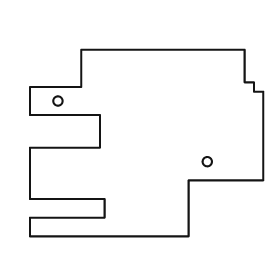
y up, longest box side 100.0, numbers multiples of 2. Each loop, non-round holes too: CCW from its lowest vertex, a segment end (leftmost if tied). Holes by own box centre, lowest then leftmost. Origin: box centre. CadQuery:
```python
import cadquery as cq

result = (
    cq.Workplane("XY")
    .moveTo(-50.0, -40.0)
    .lineTo(18.0, -40.0)
    .lineTo(18.0, -16.0)
    .lineTo(50.0, -16.0)
    .lineTo(50.0, 22.0)
    .lineTo(46.0, 22.0)
    .lineTo(46.0, 26.0)
    .lineTo(42.0, 26.0)
    .lineTo(42.0, 40.0)
    .lineTo(-28.0, 40.0)
    .lineTo(-28.0, 24.0)
    .lineTo(-50.0, 24.0)
    .lineTo(-50.0, 12.0)
    .lineTo(-20.0, 12.0)
    .lineTo(-20.0, -2.0)
    .lineTo(-50.0, -2.0)
    .lineTo(-50.0, -24.0)
    .lineTo(-18.0, -24.0)
    .lineTo(-18.0, -32.0)
    .lineTo(-50.0, -32.0)
    .close()
    .moveTo(26.0, -8.0)
    .circle(2.0)
    .moveTo(-38.0, 18.0)
    .circle(2.0)
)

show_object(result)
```